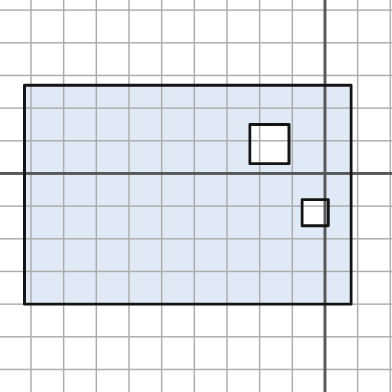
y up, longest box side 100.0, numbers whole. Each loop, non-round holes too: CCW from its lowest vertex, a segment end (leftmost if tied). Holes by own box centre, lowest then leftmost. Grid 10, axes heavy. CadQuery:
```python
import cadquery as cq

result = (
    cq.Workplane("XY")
    .moveTo(-92.0, -40.0)
    .lineTo(8.0, -40.0)
    .lineTo(8.0, 27.0)
    .lineTo(-92.0, 27.0)
    .close()
    .moveTo(-7.0, -16.0)
    .lineTo(1.0, -16.0)
    .lineTo(1.0, -8.0)
    .lineTo(-7.0, -8.0)
    .close()
    .moveTo(-23.0, 3.0)
    .lineTo(-11.0, 3.0)
    .lineTo(-11.0, 15.0)
    .lineTo(-23.0, 15.0)
    .close()
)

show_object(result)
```